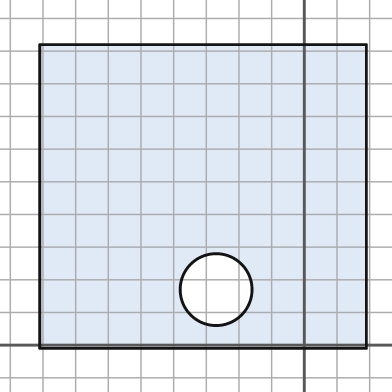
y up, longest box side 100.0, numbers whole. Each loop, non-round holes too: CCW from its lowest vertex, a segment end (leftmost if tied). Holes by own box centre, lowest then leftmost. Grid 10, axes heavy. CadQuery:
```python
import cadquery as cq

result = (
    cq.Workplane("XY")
    .moveTo(-81.0, -1.0)
    .lineTo(19.0, -1.0)
    .lineTo(19.0, 92.0)
    .lineTo(-81.0, 92.0)
    .close()
    .moveTo(-27.0, 17.0)
    .circle(11.0)
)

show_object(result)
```